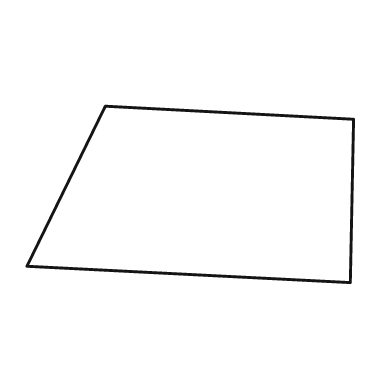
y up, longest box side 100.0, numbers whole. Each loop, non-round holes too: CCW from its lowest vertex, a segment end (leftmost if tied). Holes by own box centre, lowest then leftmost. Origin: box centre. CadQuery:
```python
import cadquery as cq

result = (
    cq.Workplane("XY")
    .moveTo(49.0, -27.0)
    .lineTo(50.0, 23.0)
    .lineTo(-26.0, 27.0)
    .lineTo(-50.0, -22.0)
    .close()
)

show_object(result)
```